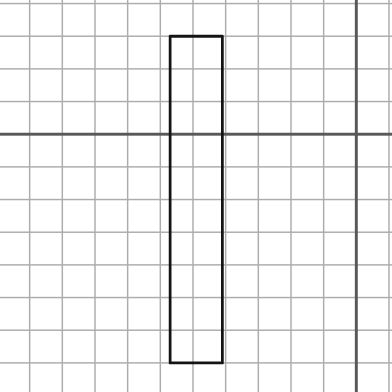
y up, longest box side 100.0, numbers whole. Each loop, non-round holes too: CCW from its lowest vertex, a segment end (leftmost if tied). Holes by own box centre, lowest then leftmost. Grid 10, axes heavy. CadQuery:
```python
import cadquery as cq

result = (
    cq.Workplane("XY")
    .moveTo(-57.0, -70.0)
    .lineTo(-41.0, -70.0)
    .lineTo(-41.0, 30.0)
    .lineTo(-57.0, 30.0)
    .close()
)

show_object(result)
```